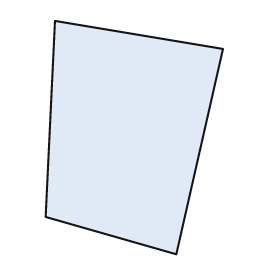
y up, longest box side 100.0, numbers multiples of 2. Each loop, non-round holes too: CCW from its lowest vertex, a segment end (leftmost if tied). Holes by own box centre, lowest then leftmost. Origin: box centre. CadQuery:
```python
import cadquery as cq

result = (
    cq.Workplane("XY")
    .moveTo(18.0, -50.0)
    .lineTo(38.0, 38.0)
    .lineTo(-34.0, 50.0)
    .lineTo(-38.0, -34.0)
    .close()
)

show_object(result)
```